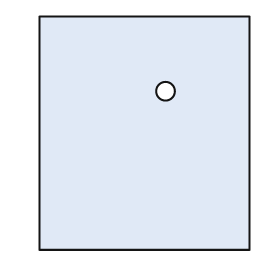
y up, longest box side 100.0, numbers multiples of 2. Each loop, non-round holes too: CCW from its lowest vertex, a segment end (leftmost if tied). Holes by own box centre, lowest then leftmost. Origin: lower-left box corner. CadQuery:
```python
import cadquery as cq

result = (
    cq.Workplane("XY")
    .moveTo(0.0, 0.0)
    .lineTo(90.0, 0.0)
    .lineTo(90.0, 100.0)
    .lineTo(0.0, 100.0)
    .close()
    .moveTo(54.0, 68.0)
    .circle(4.0)
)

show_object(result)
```